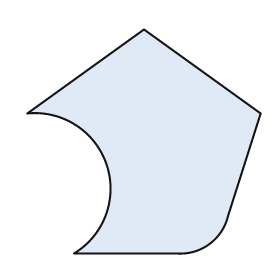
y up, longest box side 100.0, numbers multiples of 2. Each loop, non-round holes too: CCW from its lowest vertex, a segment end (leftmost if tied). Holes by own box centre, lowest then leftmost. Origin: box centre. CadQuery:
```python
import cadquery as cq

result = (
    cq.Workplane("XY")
    .moveTo(-30.0, -48.0)
    .lineTo(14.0, -48.0)
    .threePointArc((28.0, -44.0), (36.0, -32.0))
    .lineTo(50.0, 12.0)
    .lineTo(0.0, 48.0)
    .lineTo(-50.0, 12.0)
    .threePointArc((-16.0, -10.0), (-30.0, -48.0))
    .close()
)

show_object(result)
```